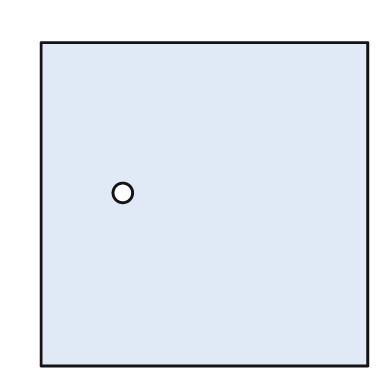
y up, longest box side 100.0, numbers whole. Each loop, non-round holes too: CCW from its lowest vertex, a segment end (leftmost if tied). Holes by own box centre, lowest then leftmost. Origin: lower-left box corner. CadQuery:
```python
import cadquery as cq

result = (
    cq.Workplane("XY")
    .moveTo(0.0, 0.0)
    .lineTo(100.0, 0.0)
    .lineTo(100.0, 99.0)
    .lineTo(0.0, 99.0)
    .close()
    .moveTo(25.0, 53.0)
    .circle(3.0)
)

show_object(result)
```